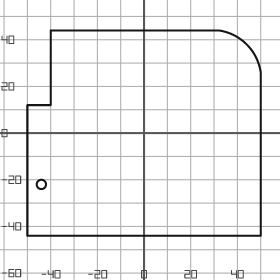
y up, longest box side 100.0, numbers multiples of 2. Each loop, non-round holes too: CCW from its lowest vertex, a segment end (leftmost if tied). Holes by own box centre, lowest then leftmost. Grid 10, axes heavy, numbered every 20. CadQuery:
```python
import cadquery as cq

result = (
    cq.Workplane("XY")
    .moveTo(-50.0, -44.0)
    .lineTo(50.0, -44.0)
    .lineTo(50.0, 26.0)
    .threePointArc((44.0, 38.0), (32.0, 44.0))
    .lineTo(-40.0, 44.0)
    .lineTo(-40.0, 12.0)
    .lineTo(-50.0, 12.0)
    .close()
    .moveTo(-44.0, -22.0)
    .circle(2.0)
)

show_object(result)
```